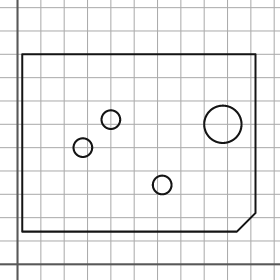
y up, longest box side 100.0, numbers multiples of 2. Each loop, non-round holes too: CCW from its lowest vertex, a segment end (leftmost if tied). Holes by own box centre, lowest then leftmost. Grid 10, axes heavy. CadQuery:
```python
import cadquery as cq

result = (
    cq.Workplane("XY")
    .moveTo(2.0, 14.0)
    .lineTo(94.0, 14.0)
    .lineTo(102.0, 22.0)
    .lineTo(102.0, 90.0)
    .lineTo(2.0, 90.0)
    .close()
    .moveTo(62.0, 34.0)
    .circle(4.0)
    .moveTo(28.0, 50.0)
    .circle(4.0)
    .moveTo(88.0, 60.0)
    .circle(8.0)
    .moveTo(40.0, 62.0)
    .circle(4.0)
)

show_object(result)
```